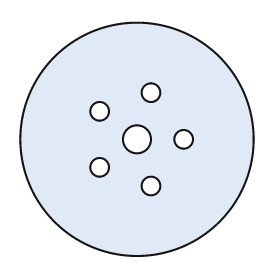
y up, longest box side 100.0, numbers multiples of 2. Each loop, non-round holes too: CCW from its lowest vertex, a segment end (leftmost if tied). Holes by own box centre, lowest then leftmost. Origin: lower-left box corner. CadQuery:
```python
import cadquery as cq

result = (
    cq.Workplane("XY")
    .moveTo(50.0, 50.0)
    .circle(50.0)
    .moveTo(56.0, 30.0)
    .circle(4.0)
    .moveTo(34.0, 38.0)
    .circle(4.0)
    .moveTo(50.0, 50.0)
    .circle(6.0)
    .moveTo(70.0, 50.0)
    .circle(4.0)
    .moveTo(34.0, 62.0)
    .circle(4.0)
    .moveTo(56.0, 70.0)
    .circle(4.0)
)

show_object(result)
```